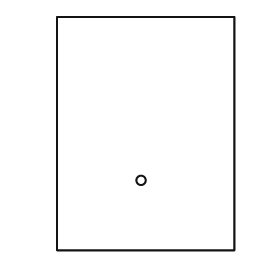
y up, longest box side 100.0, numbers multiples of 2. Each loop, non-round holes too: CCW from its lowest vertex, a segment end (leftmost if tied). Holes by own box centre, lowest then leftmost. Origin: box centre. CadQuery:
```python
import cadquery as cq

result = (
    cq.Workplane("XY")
    .moveTo(-38.0, -50.0)
    .lineTo(38.0, -50.0)
    .lineTo(38.0, 50.0)
    .lineTo(-38.0, 50.0)
    .close()
    .moveTo(-2.0, -20.0)
    .circle(2.0)
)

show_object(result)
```